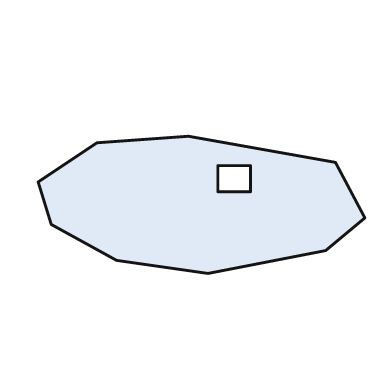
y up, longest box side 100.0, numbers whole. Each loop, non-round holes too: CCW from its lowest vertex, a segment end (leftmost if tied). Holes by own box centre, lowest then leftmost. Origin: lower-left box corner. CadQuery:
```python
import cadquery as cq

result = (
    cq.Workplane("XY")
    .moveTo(52.0, 0.0)
    .lineTo(88.0, 7.0)
    .lineTo(100.0, 17.0)
    .lineTo(91.0, 34.0)
    .lineTo(46.0, 42.0)
    .lineTo(18.0, 40.0)
    .lineTo(0.0, 28.0)
    .lineTo(4.0, 15.0)
    .lineTo(24.0, 4.0)
    .close()
    .moveTo(55.0, 25.0)
    .lineTo(65.0, 25.0)
    .lineTo(65.0, 33.0)
    .lineTo(55.0, 33.0)
    .close()
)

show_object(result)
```